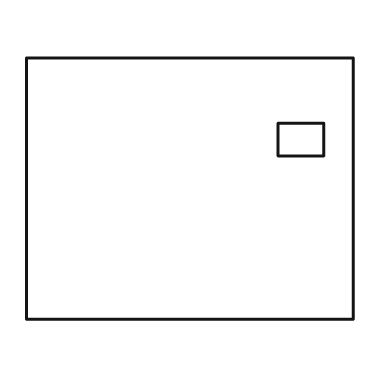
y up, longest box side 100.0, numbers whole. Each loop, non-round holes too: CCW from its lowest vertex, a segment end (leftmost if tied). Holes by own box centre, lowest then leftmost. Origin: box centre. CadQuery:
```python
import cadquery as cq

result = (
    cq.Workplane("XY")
    .moveTo(-50.0, -40.0)
    .lineTo(50.0, -40.0)
    .lineTo(50.0, 40.0)
    .lineTo(-50.0, 40.0)
    .close()
    .moveTo(27.0, 10.0)
    .lineTo(41.0, 10.0)
    .lineTo(41.0, 20.0)
    .lineTo(27.0, 20.0)
    .close()
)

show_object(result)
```